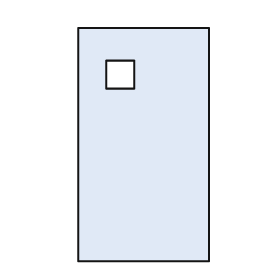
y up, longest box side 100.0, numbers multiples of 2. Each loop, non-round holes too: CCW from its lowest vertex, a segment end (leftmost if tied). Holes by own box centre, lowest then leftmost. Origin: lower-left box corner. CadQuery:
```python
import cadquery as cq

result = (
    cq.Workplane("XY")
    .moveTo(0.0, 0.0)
    .lineTo(56.0, 0.0)
    .lineTo(56.0, 100.0)
    .lineTo(0.0, 100.0)
    .close()
    .moveTo(12.0, 74.0)
    .lineTo(24.0, 74.0)
    .lineTo(24.0, 86.0)
    .lineTo(12.0, 86.0)
    .close()
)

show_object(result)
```